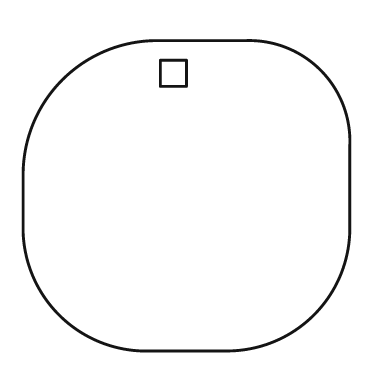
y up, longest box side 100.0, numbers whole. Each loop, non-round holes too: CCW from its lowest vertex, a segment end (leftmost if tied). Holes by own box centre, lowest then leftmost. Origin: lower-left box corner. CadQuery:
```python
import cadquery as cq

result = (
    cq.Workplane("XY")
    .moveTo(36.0, 0.0)
    .lineTo(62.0, 0.0)
    .threePointArc((89.0, 11.0), (100.0, 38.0))
    .lineTo(100.0, 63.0)
    .threePointArc((91.0, 86.0), (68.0, 95.0))
    .lineTo(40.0, 95.0)
    .threePointArc((12.0, 83.0), (0.0, 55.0))
    .lineTo(0.0, 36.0)
    .threePointArc((11.0, 11.0), (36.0, 0.0))
    .close()
    .moveTo(42.0, 81.0)
    .lineTo(50.0, 81.0)
    .lineTo(50.0, 89.0)
    .lineTo(42.0, 89.0)
    .close()
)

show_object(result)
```